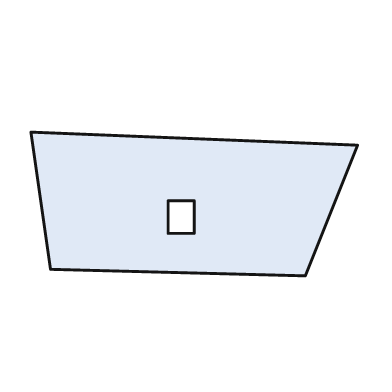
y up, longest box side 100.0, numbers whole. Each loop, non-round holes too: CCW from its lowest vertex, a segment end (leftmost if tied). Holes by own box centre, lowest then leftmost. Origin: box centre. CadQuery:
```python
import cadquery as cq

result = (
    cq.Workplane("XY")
    .moveTo(34.0, -22.0)
    .lineTo(50.0, 18.0)
    .lineTo(-50.0, 22.0)
    .lineTo(-44.0, -20.0)
    .close()
    .moveTo(-8.0, -9.0)
    .lineTo(0.0, -9.0)
    .lineTo(0.0, 1.0)
    .lineTo(-8.0, 1.0)
    .close()
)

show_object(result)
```